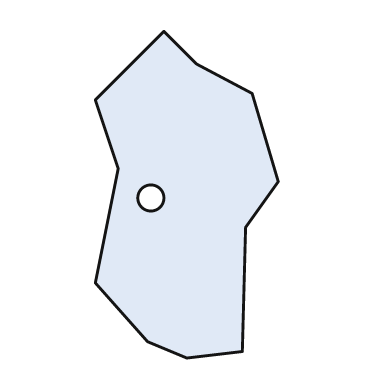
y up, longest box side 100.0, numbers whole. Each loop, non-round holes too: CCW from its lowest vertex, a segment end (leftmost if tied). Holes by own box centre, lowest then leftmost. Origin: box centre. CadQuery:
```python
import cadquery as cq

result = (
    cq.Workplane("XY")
    .moveTo(0.0, -50.0)
    .lineTo(17.0, -48.0)
    .lineTo(18.0, -10.0)
    .lineTo(28.0, 4.0)
    .lineTo(20.0, 31.0)
    .lineTo(3.0, 40.0)
    .lineTo(-7.0, 50.0)
    .lineTo(-28.0, 29.0)
    .lineTo(-21.0, 8.0)
    .lineTo(-28.0, -27.0)
    .lineTo(-12.0, -45.0)
    .close()
    .moveTo(-11.0, -1.0)
    .circle(4.0)
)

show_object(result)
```